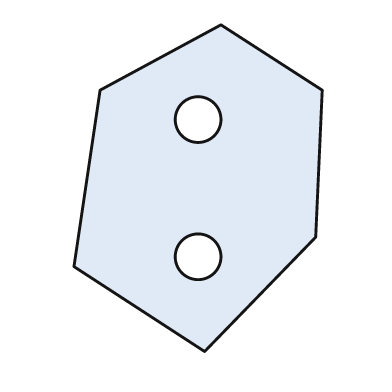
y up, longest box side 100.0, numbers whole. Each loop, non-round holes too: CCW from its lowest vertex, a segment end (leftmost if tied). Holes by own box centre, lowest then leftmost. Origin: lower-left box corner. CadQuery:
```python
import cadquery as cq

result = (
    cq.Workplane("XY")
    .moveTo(40.0, 0.0)
    .lineTo(74.0, 35.0)
    .lineTo(76.0, 80.0)
    .lineTo(45.0, 100.0)
    .lineTo(8.0, 80.0)
    .lineTo(0.0, 26.0)
    .close()
    .moveTo(38.0, 29.0)
    .circle(7.0)
    .moveTo(38.0, 71.0)
    .circle(7.0)
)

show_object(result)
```